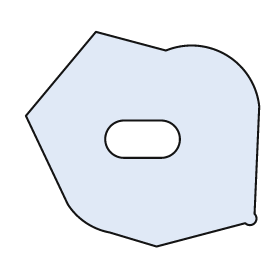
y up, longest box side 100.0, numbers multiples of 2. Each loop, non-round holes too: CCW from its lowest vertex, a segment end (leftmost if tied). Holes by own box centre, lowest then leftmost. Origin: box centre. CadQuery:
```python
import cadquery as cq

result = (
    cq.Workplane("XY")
    .moveTo(6.0, -46.0)
    .lineTo(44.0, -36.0)
    .threePointArc((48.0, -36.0), (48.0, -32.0))
    .lineTo(50.0, 14.0)
    .threePointArc((36.0, 36.0), (10.0, 38.0))
    .lineTo(-20.0, 46.0)
    .lineTo(-50.0, 10.0)
    .lineTo(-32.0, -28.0)
    .threePointArc((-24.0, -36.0), (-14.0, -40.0))
    .close()
    .moveTo(-8.0, -8.0)
    .lineTo(8.0, -8.0)
    .threePointArc((16.0, 0.0), (8.0, 8.0))
    .lineTo(-8.0, 8.0)
    .threePointArc((-16.0, 0.0), (-8.0, -8.0))
    .close()
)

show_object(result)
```